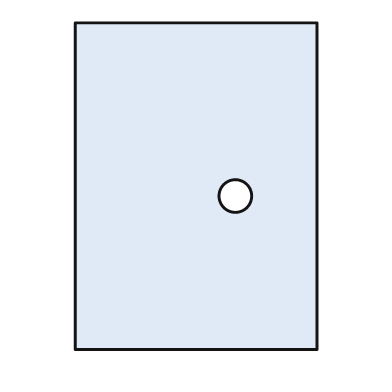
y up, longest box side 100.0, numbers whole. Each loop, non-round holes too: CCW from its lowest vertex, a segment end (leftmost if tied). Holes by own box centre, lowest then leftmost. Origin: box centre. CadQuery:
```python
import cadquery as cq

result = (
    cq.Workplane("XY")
    .moveTo(-37.0, -50.0)
    .lineTo(37.0, -50.0)
    .lineTo(37.0, 50.0)
    .lineTo(-37.0, 50.0)
    .close()
    .moveTo(12.0, -3.0)
    .circle(5.0)
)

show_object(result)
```